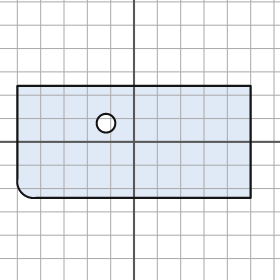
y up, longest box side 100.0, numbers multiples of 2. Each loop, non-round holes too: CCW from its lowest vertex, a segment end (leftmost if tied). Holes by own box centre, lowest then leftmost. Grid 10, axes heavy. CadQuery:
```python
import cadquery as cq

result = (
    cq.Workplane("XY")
    .moveTo(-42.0, -24.0)
    .lineTo(50.0, -24.0)
    .lineTo(50.0, 24.0)
    .lineTo(-50.0, 24.0)
    .lineTo(-50.0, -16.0)
    .threePointArc((-48.0, -22.0), (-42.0, -24.0))
    .close()
    .moveTo(-12.0, 8.0)
    .circle(4.0)
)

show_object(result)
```